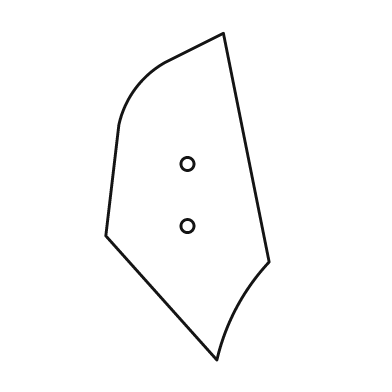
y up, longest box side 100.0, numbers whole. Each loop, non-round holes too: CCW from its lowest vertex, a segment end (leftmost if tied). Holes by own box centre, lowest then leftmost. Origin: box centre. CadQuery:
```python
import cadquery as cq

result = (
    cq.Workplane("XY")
    .moveTo(9.0, -50.0)
    .threePointArc((15.0, -34.0), (25.0, -20.0))
    .lineTo(11.0, 50.0)
    .lineTo(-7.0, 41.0)
    .threePointArc((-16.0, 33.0), (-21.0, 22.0))
    .lineTo(-25.0, -12.0)
    .close()
    .moveTo(0.0, -9.0)
    .circle(2.0)
    .moveTo(0.0, 10.0)
    .circle(2.0)
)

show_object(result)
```